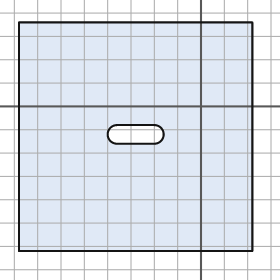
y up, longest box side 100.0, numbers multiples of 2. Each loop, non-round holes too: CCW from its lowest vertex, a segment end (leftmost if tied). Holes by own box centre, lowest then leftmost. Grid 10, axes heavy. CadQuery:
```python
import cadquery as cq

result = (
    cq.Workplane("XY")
    .moveTo(-78.0, -62.0)
    .lineTo(22.0, -62.0)
    .lineTo(22.0, 36.0)
    .lineTo(-78.0, 36.0)
    .close()
    .moveTo(-36.0, -16.0)
    .lineTo(-20.0, -16.0)
    .threePointArc((-16.0, -12.0), (-20.0, -8.0))
    .lineTo(-36.0, -8.0)
    .threePointArc((-40.0, -12.0), (-36.0, -16.0))
    .close()
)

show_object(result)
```